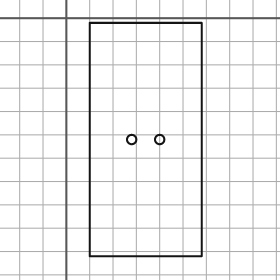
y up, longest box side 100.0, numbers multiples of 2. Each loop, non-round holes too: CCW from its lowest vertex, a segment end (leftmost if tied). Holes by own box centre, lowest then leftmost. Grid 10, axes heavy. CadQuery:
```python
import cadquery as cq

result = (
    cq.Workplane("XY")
    .moveTo(10.0, -102.0)
    .lineTo(58.0, -102.0)
    .lineTo(58.0, -2.0)
    .lineTo(10.0, -2.0)
    .close()
    .moveTo(28.0, -52.0)
    .circle(2.0)
    .moveTo(40.0, -52.0)
    .circle(2.0)
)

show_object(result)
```